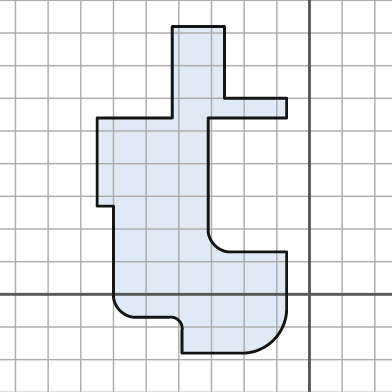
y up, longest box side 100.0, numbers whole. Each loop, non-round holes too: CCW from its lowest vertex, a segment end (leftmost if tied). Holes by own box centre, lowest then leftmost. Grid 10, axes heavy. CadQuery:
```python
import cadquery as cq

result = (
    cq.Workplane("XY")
    .moveTo(-39.0, -18.0)
    .lineTo(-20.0, -18.0)
    .threePointArc((-11.0, -14.0), (-7.0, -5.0))
    .lineTo(-7.0, 13.0)
    .lineTo(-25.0, 13.0)
    .threePointArc((-29.0, 15.0), (-31.0, 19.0))
    .lineTo(-31.0, 54.0)
    .lineTo(-7.0, 54.0)
    .lineTo(-7.0, 60.0)
    .lineTo(-26.0, 60.0)
    .lineTo(-26.0, 82.0)
    .lineTo(-42.0, 82.0)
    .lineTo(-42.0, 54.0)
    .lineTo(-65.0, 54.0)
    .lineTo(-65.0, 27.0)
    .lineTo(-60.0, 27.0)
    .lineTo(-60.0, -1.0)
    .threePointArc((-58.0, -5.0), (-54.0, -7.0))
    .lineTo(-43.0, -7.0)
    .threePointArc((-40.0, -8.0), (-39.0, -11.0))
    .close()
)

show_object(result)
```